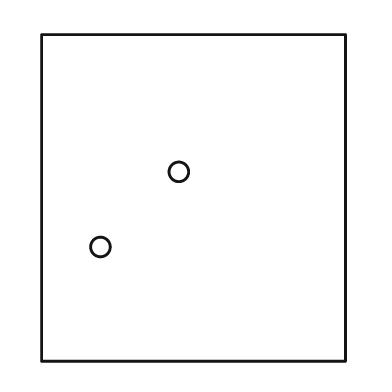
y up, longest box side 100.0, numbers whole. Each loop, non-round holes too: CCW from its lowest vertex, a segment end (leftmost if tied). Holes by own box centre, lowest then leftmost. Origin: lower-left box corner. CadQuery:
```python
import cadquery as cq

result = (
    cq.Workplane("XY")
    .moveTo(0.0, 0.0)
    .lineTo(93.0, 0.0)
    .lineTo(93.0, 100.0)
    .lineTo(0.0, 100.0)
    .close()
    .moveTo(18.0, 35.0)
    .circle(3.0)
    .moveTo(42.0, 58.0)
    .circle(3.0)
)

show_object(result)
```